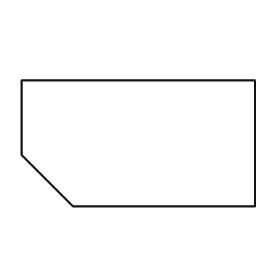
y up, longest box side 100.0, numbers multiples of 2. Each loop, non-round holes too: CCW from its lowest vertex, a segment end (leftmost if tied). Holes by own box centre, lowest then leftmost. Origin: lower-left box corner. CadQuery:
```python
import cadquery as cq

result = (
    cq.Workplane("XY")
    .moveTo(22.0, 0.0)
    .lineTo(100.0, 0.0)
    .lineTo(100.0, 54.0)
    .lineTo(0.0, 54.0)
    .lineTo(0.0, 22.0)
    .close()
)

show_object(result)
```